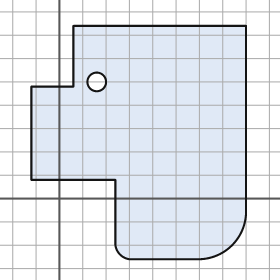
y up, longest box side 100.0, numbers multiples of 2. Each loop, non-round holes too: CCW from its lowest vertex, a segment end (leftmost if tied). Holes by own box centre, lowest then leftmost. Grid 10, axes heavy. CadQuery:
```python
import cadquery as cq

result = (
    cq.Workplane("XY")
    .moveTo(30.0, -26.0)
    .lineTo(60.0, -26.0)
    .threePointArc((74.0, -20.0), (80.0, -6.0))
    .lineTo(80.0, 74.0)
    .lineTo(6.0, 74.0)
    .lineTo(6.0, 48.0)
    .lineTo(-12.0, 48.0)
    .lineTo(-12.0, 8.0)
    .lineTo(24.0, 8.0)
    .lineTo(24.0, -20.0)
    .threePointArc((26.0, -24.0), (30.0, -26.0))
    .close()
    .moveTo(16.0, 50.0)
    .circle(4.0)
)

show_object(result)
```